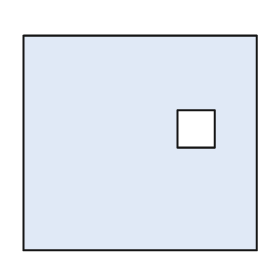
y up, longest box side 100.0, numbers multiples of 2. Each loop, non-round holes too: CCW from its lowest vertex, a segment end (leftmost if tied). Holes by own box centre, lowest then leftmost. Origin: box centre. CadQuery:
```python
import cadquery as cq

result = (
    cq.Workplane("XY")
    .moveTo(-50.0, -46.0)
    .lineTo(50.0, -46.0)
    .lineTo(50.0, 46.0)
    .lineTo(-50.0, 46.0)
    .close()
    .moveTo(16.0, -2.0)
    .lineTo(32.0, -2.0)
    .lineTo(32.0, 14.0)
    .lineTo(16.0, 14.0)
    .close()
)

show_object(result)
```